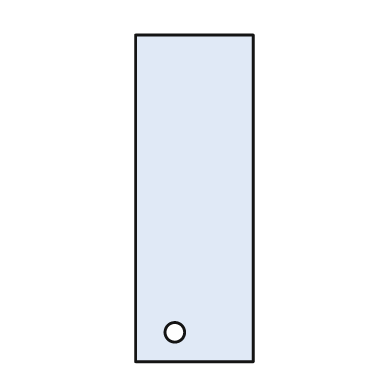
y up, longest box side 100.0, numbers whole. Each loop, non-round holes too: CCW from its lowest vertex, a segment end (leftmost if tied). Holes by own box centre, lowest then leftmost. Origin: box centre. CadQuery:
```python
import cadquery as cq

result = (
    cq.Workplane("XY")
    .moveTo(-18.0, -50.0)
    .lineTo(18.0, -50.0)
    .lineTo(18.0, 50.0)
    .lineTo(-18.0, 50.0)
    .close()
    .moveTo(-6.0, -41.0)
    .circle(3.0)
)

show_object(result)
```